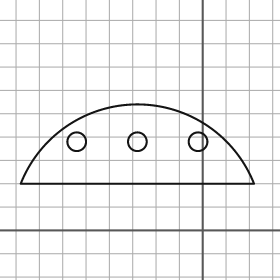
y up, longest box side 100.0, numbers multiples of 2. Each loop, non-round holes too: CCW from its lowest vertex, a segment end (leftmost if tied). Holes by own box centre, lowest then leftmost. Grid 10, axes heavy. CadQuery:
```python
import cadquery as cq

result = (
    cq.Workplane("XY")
    .moveTo(-78.0, 20.0)
    .lineTo(22.0, 20.0)
    .threePointArc((-28.0, 54.0), (-78.0, 20.0))
    .close()
    .moveTo(-54.0, 38.0)
    .circle(4.0)
    .moveTo(-28.0, 38.0)
    .circle(4.0)
    .moveTo(-2.0, 38.0)
    .circle(4.0)
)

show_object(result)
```